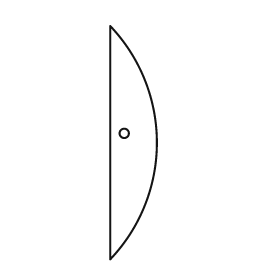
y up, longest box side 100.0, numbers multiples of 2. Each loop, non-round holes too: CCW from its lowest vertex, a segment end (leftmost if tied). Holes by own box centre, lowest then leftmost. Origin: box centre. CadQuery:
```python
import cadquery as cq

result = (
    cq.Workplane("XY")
    .moveTo(-10.0, -50.0)
    .threePointArc((10.0, 0.0), (-10.0, 50.0))
    .close()
    .moveTo(-4.0, 4.0)
    .circle(2.0)
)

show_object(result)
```